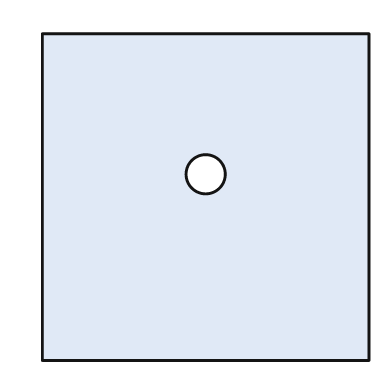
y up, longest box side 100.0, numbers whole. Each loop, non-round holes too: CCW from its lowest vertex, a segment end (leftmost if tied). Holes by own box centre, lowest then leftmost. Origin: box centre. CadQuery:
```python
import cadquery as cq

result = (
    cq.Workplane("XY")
    .moveTo(-50.0, -50.0)
    .lineTo(50.0, -50.0)
    .lineTo(50.0, 50.0)
    .lineTo(-50.0, 50.0)
    .close()
    .moveTo(0.0, 7.0)
    .circle(6.0)
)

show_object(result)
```